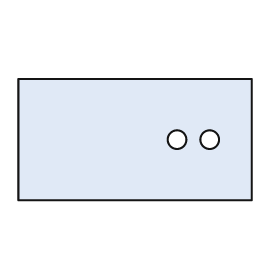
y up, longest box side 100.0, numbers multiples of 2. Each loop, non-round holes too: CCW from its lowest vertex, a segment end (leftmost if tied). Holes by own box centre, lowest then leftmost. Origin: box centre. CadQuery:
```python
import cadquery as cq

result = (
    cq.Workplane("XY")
    .moveTo(-50.0, -26.0)
    .lineTo(50.0, -26.0)
    .lineTo(50.0, 26.0)
    .lineTo(-50.0, 26.0)
    .close()
    .moveTo(18.0, 0.0)
    .circle(4.0)
    .moveTo(32.0, 0.0)
    .circle(4.0)
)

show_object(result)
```